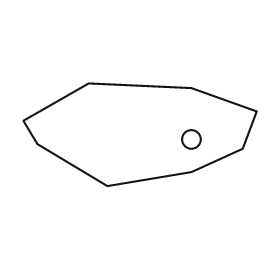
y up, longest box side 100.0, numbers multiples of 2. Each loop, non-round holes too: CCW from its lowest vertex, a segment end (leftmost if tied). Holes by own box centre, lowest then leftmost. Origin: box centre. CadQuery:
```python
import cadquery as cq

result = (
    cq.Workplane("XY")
    .moveTo(-14.0, -22.0)
    .lineTo(22.0, -16.0)
    .lineTo(44.0, -6.0)
    .lineTo(50.0, 10.0)
    .lineTo(22.0, 20.0)
    .lineTo(-22.0, 22.0)
    .lineTo(-50.0, 6.0)
    .lineTo(-44.0, -4.0)
    .close()
    .moveTo(22.0, -2.0)
    .circle(4.0)
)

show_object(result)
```